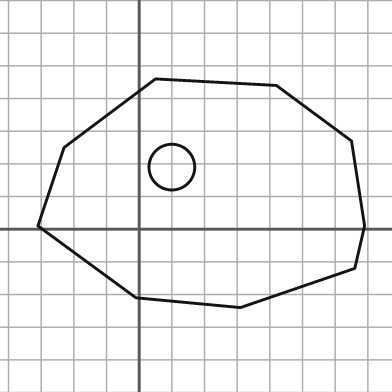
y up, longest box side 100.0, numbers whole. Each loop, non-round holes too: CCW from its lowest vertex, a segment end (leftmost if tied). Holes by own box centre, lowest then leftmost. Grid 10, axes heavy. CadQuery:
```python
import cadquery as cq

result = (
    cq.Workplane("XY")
    .moveTo(31.0, -24.0)
    .lineTo(66.0, -12.0)
    .lineTo(69.0, 1.0)
    .lineTo(65.0, 27.0)
    .lineTo(42.0, 44.0)
    .lineTo(5.0, 46.0)
    .lineTo(-23.0, 25.0)
    .lineTo(-31.0, 1.0)
    .lineTo(-1.0, -21.0)
    .close()
    .moveTo(10.0, 19.0)
    .circle(7.0)
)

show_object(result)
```